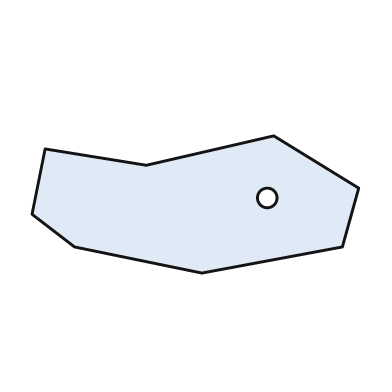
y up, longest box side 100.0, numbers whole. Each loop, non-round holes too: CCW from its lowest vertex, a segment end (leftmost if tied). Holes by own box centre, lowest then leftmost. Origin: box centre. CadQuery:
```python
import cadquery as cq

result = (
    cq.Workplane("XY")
    .moveTo(2.0, -21.0)
    .lineTo(45.0, -13.0)
    .lineTo(50.0, 5.0)
    .lineTo(24.0, 21.0)
    .lineTo(-15.0, 12.0)
    .lineTo(-46.0, 17.0)
    .lineTo(-50.0, -3.0)
    .lineTo(-37.0, -13.0)
    .close()
    .moveTo(22.0, 2.0)
    .circle(3.0)
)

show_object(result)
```